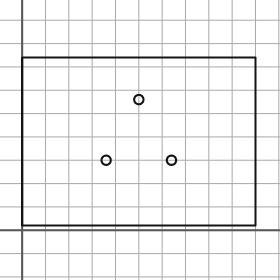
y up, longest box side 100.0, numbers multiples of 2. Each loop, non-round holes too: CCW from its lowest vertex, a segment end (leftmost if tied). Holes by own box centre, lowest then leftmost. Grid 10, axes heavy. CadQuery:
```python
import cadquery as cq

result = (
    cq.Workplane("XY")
    .moveTo(0.0, 2.0)
    .lineTo(100.0, 2.0)
    .lineTo(100.0, 74.0)
    .lineTo(0.0, 74.0)
    .close()
    .moveTo(36.0, 30.0)
    .circle(2.0)
    .moveTo(64.0, 30.0)
    .circle(2.0)
    .moveTo(50.0, 56.0)
    .circle(2.0)
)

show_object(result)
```